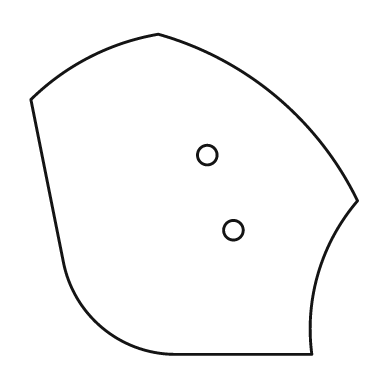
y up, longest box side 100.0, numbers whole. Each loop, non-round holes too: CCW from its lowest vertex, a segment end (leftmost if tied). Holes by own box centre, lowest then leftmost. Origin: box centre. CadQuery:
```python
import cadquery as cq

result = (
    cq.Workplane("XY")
    .moveTo(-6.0, -49.0)
    .lineTo(36.0, -49.0)
    .threePointArc((38.0, -24.0), (50.0, -2.0))
    .threePointArc((25.0, 30.0), (-11.0, 49.0))
    .threePointArc((-32.0, 42.0), (-50.0, 29.0))
    .lineTo(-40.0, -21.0)
    .threePointArc((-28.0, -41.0), (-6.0, -49.0))
    .close()
    .moveTo(12.0, -11.0)
    .circle(3.0)
    .moveTo(4.0, 12.0)
    .circle(3.0)
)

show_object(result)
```